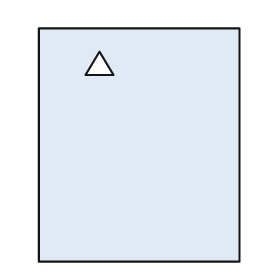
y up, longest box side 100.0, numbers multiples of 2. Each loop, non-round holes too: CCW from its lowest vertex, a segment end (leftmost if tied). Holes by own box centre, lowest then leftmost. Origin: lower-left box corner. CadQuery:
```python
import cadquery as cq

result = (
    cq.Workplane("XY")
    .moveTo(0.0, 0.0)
    .lineTo(86.0, 0.0)
    .lineTo(86.0, 100.0)
    .lineTo(0.0, 100.0)
    .close()
    .moveTo(20.0, 80.0)
    .lineTo(32.0, 80.0)
    .lineTo(26.0, 90.0)
    .close()
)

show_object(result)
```